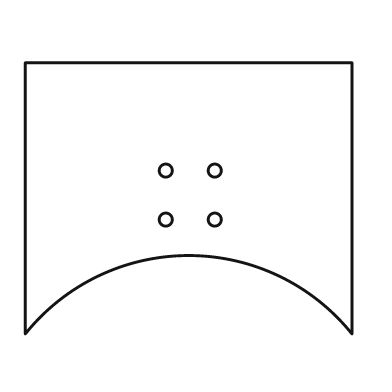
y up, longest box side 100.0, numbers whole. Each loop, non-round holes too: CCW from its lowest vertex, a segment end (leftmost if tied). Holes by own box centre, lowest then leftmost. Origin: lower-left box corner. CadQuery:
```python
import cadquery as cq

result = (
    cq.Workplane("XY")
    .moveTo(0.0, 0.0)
    .threePointArc((50.0, 24.0), (100.0, 0.0))
    .lineTo(100.0, 83.0)
    .lineTo(0.0, 83.0)
    .close()
    .moveTo(43.0, 35.0)
    .circle(2.0)
    .moveTo(58.0, 35.0)
    .circle(2.0)
    .moveTo(43.0, 50.0)
    .circle(2.0)
    .moveTo(58.0, 50.0)
    .circle(2.0)
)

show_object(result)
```